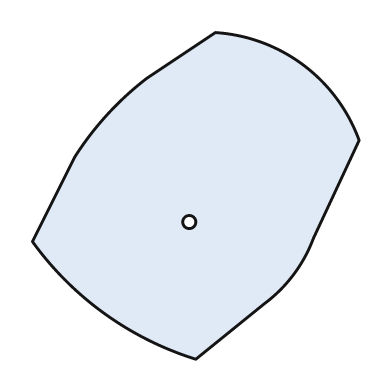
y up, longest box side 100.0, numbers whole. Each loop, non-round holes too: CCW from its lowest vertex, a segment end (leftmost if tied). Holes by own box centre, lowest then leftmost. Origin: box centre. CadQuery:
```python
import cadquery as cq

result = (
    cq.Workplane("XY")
    .moveTo(0.0, -50.0)
    .lineTo(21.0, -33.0)
    .threePointArc((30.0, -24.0), (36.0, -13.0))
    .lineTo(50.0, 17.0)
    .threePointArc((33.0, 40.0), (6.0, 50.0))
    .lineTo(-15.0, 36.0)
    .threePointArc((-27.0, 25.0), (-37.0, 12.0))
    .lineTo(-50.0, -14.0)
    .threePointArc((-28.0, -36.0), (0.0, -50.0))
    .close()
    .moveTo(-2.0, -8.0)
    .circle(2.0)
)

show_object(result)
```